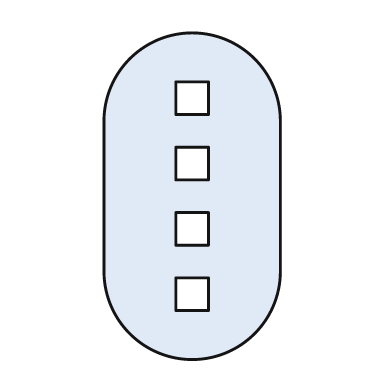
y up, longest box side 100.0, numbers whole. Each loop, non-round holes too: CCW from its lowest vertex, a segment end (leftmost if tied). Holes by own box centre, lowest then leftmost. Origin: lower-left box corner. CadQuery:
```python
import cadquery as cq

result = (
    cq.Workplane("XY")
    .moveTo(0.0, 27.0)
    .threePointArc((27.0, 0.0), (54.0, 27.0))
    .lineTo(54.0, 73.0)
    .threePointArc((27.0, 100.0), (0.0, 73.0))
    .close()
    .moveTo(22.0, 15.0)
    .lineTo(32.0, 15.0)
    .lineTo(32.0, 25.0)
    .lineTo(22.0, 25.0)
    .close()
    .moveTo(22.0, 35.0)
    .lineTo(32.0, 35.0)
    .lineTo(32.0, 45.0)
    .lineTo(22.0, 45.0)
    .close()
    .moveTo(22.0, 55.0)
    .lineTo(32.0, 55.0)
    .lineTo(32.0, 65.0)
    .lineTo(22.0, 65.0)
    .close()
    .moveTo(22.0, 75.0)
    .lineTo(32.0, 75.0)
    .lineTo(32.0, 85.0)
    .lineTo(22.0, 85.0)
    .close()
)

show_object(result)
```